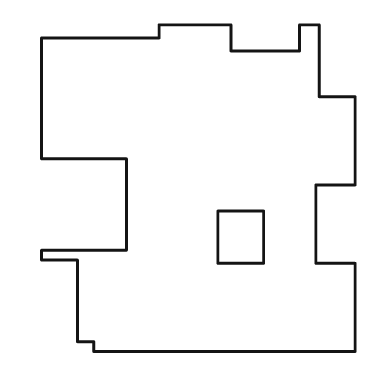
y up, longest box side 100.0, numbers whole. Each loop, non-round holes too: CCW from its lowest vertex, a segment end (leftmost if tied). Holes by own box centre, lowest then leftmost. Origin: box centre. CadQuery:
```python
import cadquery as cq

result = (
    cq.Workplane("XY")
    .moveTo(-32.0, -50.0)
    .lineTo(48.0, -50.0)
    .lineTo(48.0, -23.0)
    .lineTo(36.0, -23.0)
    .lineTo(36.0, 1.0)
    .lineTo(48.0, 1.0)
    .lineTo(48.0, 28.0)
    .lineTo(37.0, 28.0)
    .lineTo(37.0, 50.0)
    .lineTo(31.0, 50.0)
    .lineTo(31.0, 42.0)
    .lineTo(10.0, 42.0)
    .lineTo(10.0, 50.0)
    .lineTo(-12.0, 50.0)
    .lineTo(-12.0, 46.0)
    .lineTo(-48.0, 46.0)
    .lineTo(-48.0, 9.0)
    .lineTo(-22.0, 9.0)
    .lineTo(-22.0, -19.0)
    .lineTo(-48.0, -19.0)
    .lineTo(-48.0, -22.0)
    .lineTo(-37.0, -22.0)
    .lineTo(-37.0, -47.0)
    .lineTo(-32.0, -47.0)
    .close()
    .moveTo(6.0, -23.0)
    .lineTo(20.0, -23.0)
    .lineTo(20.0, -7.0)
    .lineTo(6.0, -7.0)
    .close()
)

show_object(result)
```